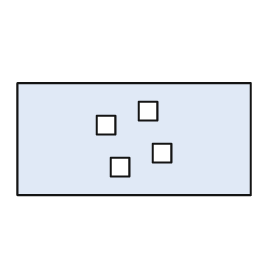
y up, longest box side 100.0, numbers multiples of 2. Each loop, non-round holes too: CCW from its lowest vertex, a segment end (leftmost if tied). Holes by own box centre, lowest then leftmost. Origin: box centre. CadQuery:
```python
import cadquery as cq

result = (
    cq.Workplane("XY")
    .moveTo(-50.0, -24.0)
    .lineTo(50.0, -24.0)
    .lineTo(50.0, 24.0)
    .lineTo(-50.0, 24.0)
    .close()
    .moveTo(-10.0, -16.0)
    .lineTo(-2.0, -16.0)
    .lineTo(-2.0, -8.0)
    .lineTo(-10.0, -8.0)
    .close()
    .moveTo(8.0, -10.0)
    .lineTo(16.0, -10.0)
    .lineTo(16.0, -2.0)
    .lineTo(8.0, -2.0)
    .close()
    .moveTo(-16.0, 2.0)
    .lineTo(-8.0, 2.0)
    .lineTo(-8.0, 10.0)
    .lineTo(-16.0, 10.0)
    .close()
    .moveTo(2.0, 8.0)
    .lineTo(10.0, 8.0)
    .lineTo(10.0, 16.0)
    .lineTo(2.0, 16.0)
    .close()
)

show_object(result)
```